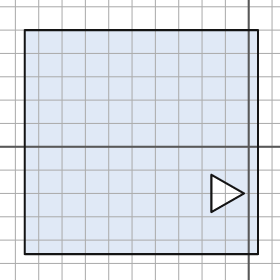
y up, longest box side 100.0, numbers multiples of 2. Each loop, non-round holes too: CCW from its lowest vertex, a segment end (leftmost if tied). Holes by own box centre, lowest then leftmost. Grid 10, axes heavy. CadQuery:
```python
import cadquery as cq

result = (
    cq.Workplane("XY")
    .moveTo(-96.0, -46.0)
    .lineTo(4.0, -46.0)
    .lineTo(4.0, 50.0)
    .lineTo(-96.0, 50.0)
    .close()
    .moveTo(-16.0, -28.0)
    .lineTo(-2.0, -20.0)
    .lineTo(-16.0, -12.0)
    .close()
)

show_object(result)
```